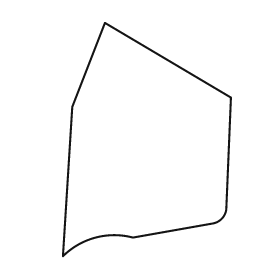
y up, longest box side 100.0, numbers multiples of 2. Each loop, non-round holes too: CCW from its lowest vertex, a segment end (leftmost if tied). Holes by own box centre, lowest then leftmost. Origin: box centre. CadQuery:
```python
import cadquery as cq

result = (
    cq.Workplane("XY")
    .moveTo(-36.0, -50.0)
    .threePointArc((-22.0, -42.0), (-6.0, -42.0))
    .lineTo(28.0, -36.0)
    .threePointArc((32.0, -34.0), (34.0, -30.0))
    .lineTo(36.0, 18.0)
    .lineTo(-18.0, 50.0)
    .lineTo(-32.0, 14.0)
    .close()
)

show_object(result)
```